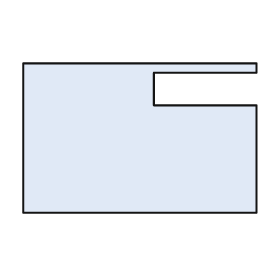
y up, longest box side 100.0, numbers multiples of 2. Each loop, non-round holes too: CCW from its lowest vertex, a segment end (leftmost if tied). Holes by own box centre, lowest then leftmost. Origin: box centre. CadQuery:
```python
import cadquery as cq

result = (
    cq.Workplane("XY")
    .moveTo(-50.0, -32.0)
    .lineTo(50.0, -32.0)
    .lineTo(50.0, 14.0)
    .lineTo(6.0, 14.0)
    .lineTo(6.0, 28.0)
    .lineTo(50.0, 28.0)
    .lineTo(50.0, 32.0)
    .lineTo(-50.0, 32.0)
    .close()
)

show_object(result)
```